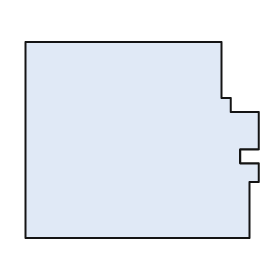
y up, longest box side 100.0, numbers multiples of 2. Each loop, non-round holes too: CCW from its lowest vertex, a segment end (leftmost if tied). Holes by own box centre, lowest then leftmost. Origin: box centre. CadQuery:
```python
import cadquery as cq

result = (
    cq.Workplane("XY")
    .moveTo(-50.0, -42.0)
    .lineTo(46.0, -42.0)
    .lineTo(46.0, -18.0)
    .lineTo(50.0, -18.0)
    .lineTo(50.0, -10.0)
    .lineTo(42.0, -10.0)
    .lineTo(42.0, -4.0)
    .lineTo(50.0, -4.0)
    .lineTo(50.0, 12.0)
    .lineTo(38.0, 12.0)
    .lineTo(38.0, 18.0)
    .lineTo(34.0, 18.0)
    .lineTo(34.0, 42.0)
    .lineTo(-50.0, 42.0)
    .close()
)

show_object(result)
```